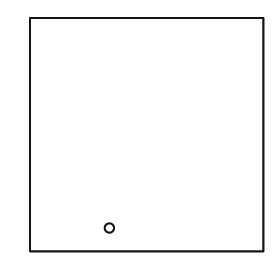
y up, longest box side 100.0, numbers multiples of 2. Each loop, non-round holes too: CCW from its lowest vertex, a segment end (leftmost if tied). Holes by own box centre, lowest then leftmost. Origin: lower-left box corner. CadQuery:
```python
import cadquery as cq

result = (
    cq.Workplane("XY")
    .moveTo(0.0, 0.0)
    .lineTo(100.0, 0.0)
    .lineTo(100.0, 100.0)
    .lineTo(0.0, 100.0)
    .close()
    .moveTo(34.0, 10.0)
    .circle(2.0)
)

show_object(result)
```